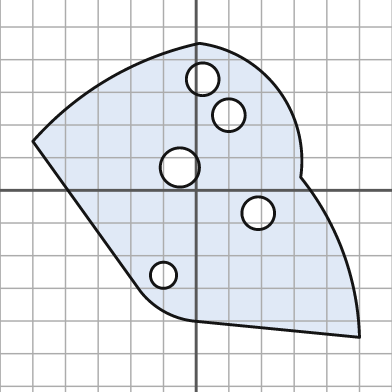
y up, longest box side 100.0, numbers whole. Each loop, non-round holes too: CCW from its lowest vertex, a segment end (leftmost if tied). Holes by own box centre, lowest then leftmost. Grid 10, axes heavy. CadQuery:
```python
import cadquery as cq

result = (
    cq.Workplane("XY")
    .moveTo(50.0, -45.0)
    .threePointArc((45.0, -19.0), (32.0, 4.0))
    .threePointArc((25.0, 31.0), (1.0, 45.0))
    .threePointArc((-27.0, 34.0), (-50.0, 15.0))
    .lineTo(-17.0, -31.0)
    .threePointArc((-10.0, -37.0), (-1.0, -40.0))
    .close()
    .moveTo(-10.0, -26.0)
    .circle(4.0)
    .moveTo(19.0, -7.0)
    .circle(5.0)
    .moveTo(-5.0, 7.0)
    .circle(6.0)
    .moveTo(10.0, 23.0)
    .circle(5.0)
    .moveTo(2.0, 34.0)
    .circle(5.0)
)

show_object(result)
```